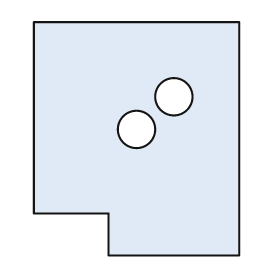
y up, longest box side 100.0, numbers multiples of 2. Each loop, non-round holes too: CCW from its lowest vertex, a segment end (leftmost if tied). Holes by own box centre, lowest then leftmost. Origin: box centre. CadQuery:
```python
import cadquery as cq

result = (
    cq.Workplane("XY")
    .moveTo(-12.0, -50.0)
    .lineTo(44.0, -50.0)
    .lineTo(44.0, 50.0)
    .lineTo(-44.0, 50.0)
    .lineTo(-44.0, -32.0)
    .lineTo(-12.0, -32.0)
    .close()
    .moveTo(0.0, 4.0)
    .circle(8.0)
    .moveTo(16.0, 18.0)
    .circle(8.0)
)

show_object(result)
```